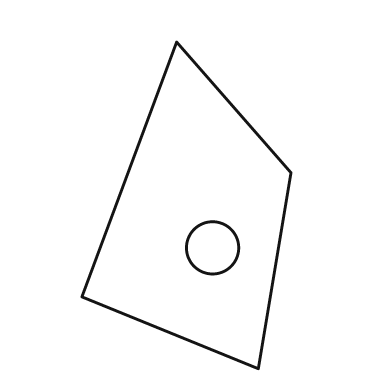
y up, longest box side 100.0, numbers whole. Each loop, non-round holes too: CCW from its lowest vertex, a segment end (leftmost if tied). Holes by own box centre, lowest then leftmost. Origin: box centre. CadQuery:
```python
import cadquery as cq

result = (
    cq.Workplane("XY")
    .moveTo(22.0, -50.0)
    .lineTo(32.0, 10.0)
    .lineTo(-3.0, 50.0)
    .lineTo(-32.0, -28.0)
    .close()
    .moveTo(8.0, -13.0)
    .circle(8.0)
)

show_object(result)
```